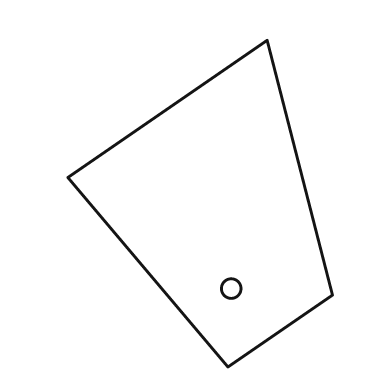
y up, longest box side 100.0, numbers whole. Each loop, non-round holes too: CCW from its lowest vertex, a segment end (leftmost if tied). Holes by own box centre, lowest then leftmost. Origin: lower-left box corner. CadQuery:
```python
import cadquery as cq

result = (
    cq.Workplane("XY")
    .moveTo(49.0, 0.0)
    .lineTo(81.0, 22.0)
    .lineTo(61.0, 100.0)
    .lineTo(0.0, 58.0)
    .close()
    .moveTo(50.0, 24.0)
    .circle(3.0)
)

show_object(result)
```